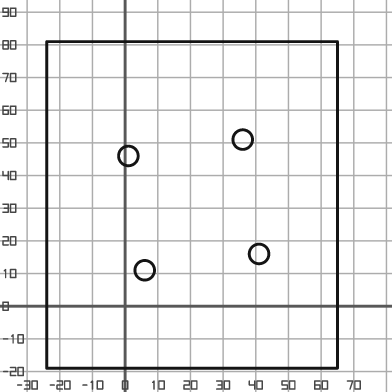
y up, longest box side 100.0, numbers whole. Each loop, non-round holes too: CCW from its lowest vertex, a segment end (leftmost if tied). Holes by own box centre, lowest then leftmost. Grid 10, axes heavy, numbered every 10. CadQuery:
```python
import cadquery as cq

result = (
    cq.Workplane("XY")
    .moveTo(-24.0, -19.0)
    .lineTo(65.0, -19.0)
    .lineTo(65.0, 81.0)
    .lineTo(-24.0, 81.0)
    .close()
    .moveTo(6.0, 11.0)
    .circle(3.0)
    .moveTo(41.0, 16.0)
    .circle(3.0)
    .moveTo(1.0, 46.0)
    .circle(3.0)
    .moveTo(36.0, 51.0)
    .circle(3.0)
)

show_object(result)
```